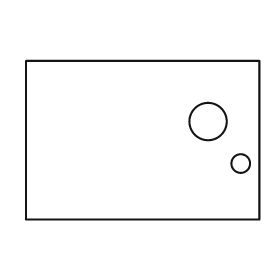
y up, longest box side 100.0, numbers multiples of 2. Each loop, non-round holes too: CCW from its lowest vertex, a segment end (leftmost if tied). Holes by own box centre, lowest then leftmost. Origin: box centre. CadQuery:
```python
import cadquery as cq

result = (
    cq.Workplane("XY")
    .moveTo(-50.0, -34.0)
    .lineTo(50.0, -34.0)
    .lineTo(50.0, 34.0)
    .lineTo(-50.0, 34.0)
    .close()
    .moveTo(42.0, -10.0)
    .circle(4.0)
    .moveTo(28.0, 8.0)
    .circle(8.0)
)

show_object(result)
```